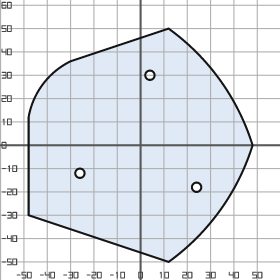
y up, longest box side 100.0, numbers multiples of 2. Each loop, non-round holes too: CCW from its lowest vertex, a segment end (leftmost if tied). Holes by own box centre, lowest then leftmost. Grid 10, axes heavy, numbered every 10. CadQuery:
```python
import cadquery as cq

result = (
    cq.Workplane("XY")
    .moveTo(12.0, -50.0)
    .threePointArc((34.0, -28.0), (48.0, 0.0))
    .threePointArc((34.0, 28.0), (12.0, 50.0))
    .lineTo(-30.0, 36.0)
    .threePointArc((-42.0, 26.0), (-48.0, 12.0))
    .lineTo(-48.0, -30.0)
    .close()
    .moveTo(24.0, -18.0)
    .circle(2.0)
    .moveTo(-26.0, -12.0)
    .circle(2.0)
    .moveTo(4.0, 30.0)
    .circle(2.0)
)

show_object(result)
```